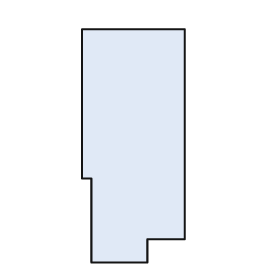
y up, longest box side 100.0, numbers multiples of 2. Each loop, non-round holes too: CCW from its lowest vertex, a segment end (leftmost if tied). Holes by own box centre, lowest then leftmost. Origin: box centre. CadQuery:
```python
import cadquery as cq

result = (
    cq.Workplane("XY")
    .moveTo(-18.0, -50.0)
    .lineTo(6.0, -50.0)
    .lineTo(6.0, -40.0)
    .lineTo(22.0, -40.0)
    .lineTo(22.0, 50.0)
    .lineTo(-22.0, 50.0)
    .lineTo(-22.0, -14.0)
    .lineTo(-18.0, -14.0)
    .close()
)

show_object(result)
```